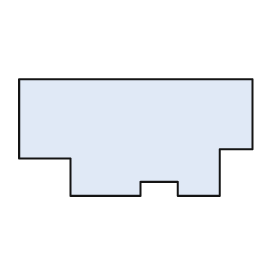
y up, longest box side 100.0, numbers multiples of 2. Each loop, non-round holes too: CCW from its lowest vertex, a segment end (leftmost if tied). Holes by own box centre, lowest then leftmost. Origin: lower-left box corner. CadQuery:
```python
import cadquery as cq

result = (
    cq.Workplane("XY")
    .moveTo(22.0, 0.0)
    .lineTo(52.0, 0.0)
    .lineTo(52.0, 6.0)
    .lineTo(68.0, 6.0)
    .lineTo(68.0, 0.0)
    .lineTo(86.0, 0.0)
    .lineTo(86.0, 20.0)
    .lineTo(100.0, 20.0)
    .lineTo(100.0, 50.0)
    .lineTo(0.0, 50.0)
    .lineTo(0.0, 16.0)
    .lineTo(22.0, 16.0)
    .close()
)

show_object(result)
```